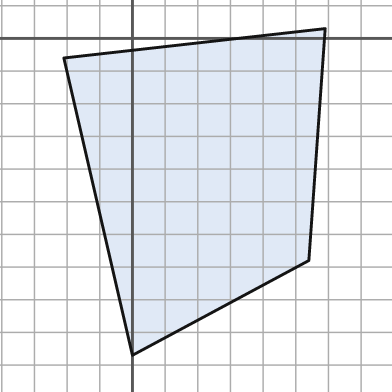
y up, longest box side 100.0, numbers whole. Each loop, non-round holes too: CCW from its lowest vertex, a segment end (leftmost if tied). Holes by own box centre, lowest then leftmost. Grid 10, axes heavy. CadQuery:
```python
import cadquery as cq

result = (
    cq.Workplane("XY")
    .moveTo(0.0, -97.0)
    .lineTo(54.0, -68.0)
    .lineTo(59.0, 3.0)
    .lineTo(-21.0, -6.0)
    .close()
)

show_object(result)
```